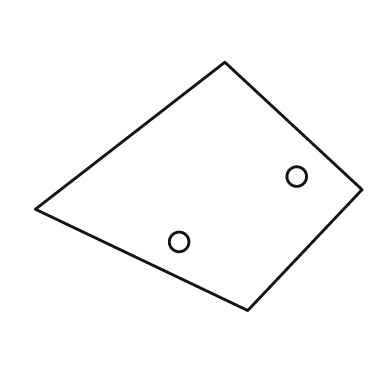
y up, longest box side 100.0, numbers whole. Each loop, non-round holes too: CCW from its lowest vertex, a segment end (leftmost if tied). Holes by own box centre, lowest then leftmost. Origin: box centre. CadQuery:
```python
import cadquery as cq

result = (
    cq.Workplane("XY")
    .moveTo(15.0, -38.0)
    .lineTo(50.0, -1.0)
    .lineTo(8.0, 38.0)
    .lineTo(-50.0, -7.0)
    .close()
    .moveTo(-6.0, -17.0)
    .circle(3.0)
    .moveTo(30.0, 3.0)
    .circle(3.0)
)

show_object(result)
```